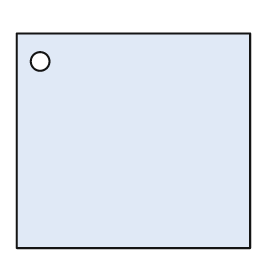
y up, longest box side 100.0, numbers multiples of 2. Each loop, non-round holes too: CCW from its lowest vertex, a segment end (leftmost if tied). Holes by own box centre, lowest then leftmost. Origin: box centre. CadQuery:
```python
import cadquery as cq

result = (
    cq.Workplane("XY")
    .moveTo(-50.0, -46.0)
    .lineTo(50.0, -46.0)
    .lineTo(50.0, 46.0)
    .lineTo(-50.0, 46.0)
    .close()
    .moveTo(-40.0, 34.0)
    .circle(4.0)
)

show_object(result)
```